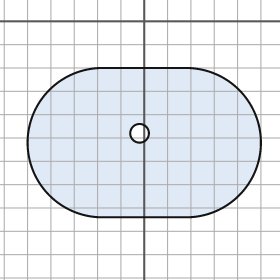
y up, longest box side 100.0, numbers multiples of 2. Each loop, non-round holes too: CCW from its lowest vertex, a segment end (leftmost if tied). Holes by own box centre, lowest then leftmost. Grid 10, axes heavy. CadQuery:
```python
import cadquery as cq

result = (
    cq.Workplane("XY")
    .moveTo(-18.0, -84.0)
    .lineTo(18.0, -84.0)
    .threePointArc((50.0, -52.0), (18.0, -20.0))
    .lineTo(-18.0, -20.0)
    .threePointArc((-50.0, -52.0), (-18.0, -84.0))
    .close()
    .moveTo(-2.0, -48.0)
    .circle(4.0)
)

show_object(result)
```